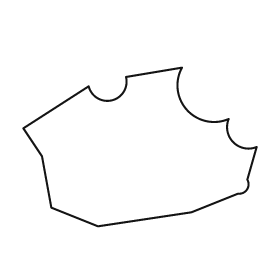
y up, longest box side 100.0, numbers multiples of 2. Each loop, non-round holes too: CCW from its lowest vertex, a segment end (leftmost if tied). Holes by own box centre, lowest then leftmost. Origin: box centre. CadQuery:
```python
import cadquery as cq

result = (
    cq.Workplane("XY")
    .moveTo(-18.0, -34.0)
    .lineTo(22.0, -28.0)
    .lineTo(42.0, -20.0)
    .threePointArc((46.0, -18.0), (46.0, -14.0))
    .lineTo(50.0, 0.0)
    .threePointArc((40.0, 2.0), (38.0, 12.0))
    .threePointArc((20.0, 16.0), (18.0, 34.0))
    .lineTo(-6.0, 30.0)
    .threePointArc((-12.0, 20.0), (-22.0, 26.0))
    .lineTo(-50.0, 8.0)
    .lineTo(-42.0, -4.0)
    .lineTo(-38.0, -26.0)
    .close()
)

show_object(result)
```